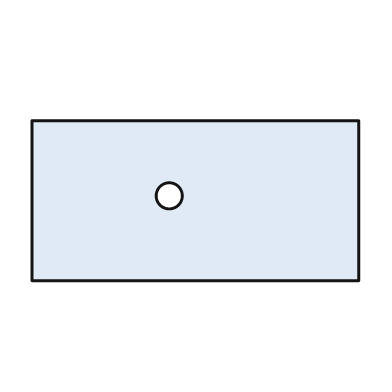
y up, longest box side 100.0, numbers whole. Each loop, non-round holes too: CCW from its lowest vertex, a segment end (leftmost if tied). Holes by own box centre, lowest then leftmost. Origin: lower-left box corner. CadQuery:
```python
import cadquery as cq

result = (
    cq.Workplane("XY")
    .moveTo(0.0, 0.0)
    .lineTo(100.0, 0.0)
    .lineTo(100.0, 49.0)
    .lineTo(0.0, 49.0)
    .close()
    .moveTo(42.0, 26.0)
    .circle(4.0)
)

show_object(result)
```